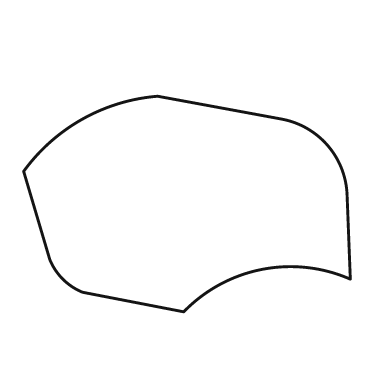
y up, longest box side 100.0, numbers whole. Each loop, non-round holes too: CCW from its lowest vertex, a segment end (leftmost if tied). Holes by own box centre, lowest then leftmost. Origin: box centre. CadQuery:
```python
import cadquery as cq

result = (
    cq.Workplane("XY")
    .moveTo(-1.0, -33.0)
    .threePointArc((23.0, -20.0), (50.0, -23.0))
    .lineTo(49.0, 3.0)
    .threePointArc((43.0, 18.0), (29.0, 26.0))
    .lineTo(-9.0, 33.0)
    .threePointArc((-32.0, 26.0), (-50.0, 10.0))
    .lineTo(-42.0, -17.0)
    .threePointArc((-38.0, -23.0), (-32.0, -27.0))
    .close()
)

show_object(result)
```